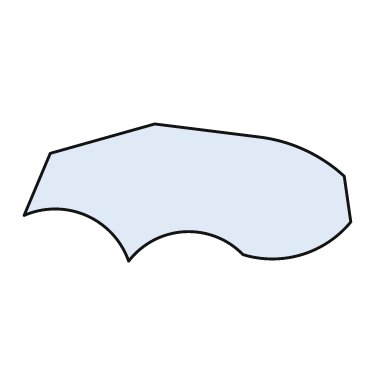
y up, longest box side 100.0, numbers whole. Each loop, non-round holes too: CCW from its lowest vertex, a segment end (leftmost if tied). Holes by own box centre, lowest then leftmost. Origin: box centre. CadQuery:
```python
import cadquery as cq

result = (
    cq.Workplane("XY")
    .moveTo(-18.0, -21.0)
    .threePointArc((-1.0, -12.0), (17.0, -19.0))
    .threePointArc((35.0, -19.0), (50.0, -9.0))
    .lineTo(48.0, 5.0)
    .threePointArc((36.0, 13.0), (22.0, 17.0))
    .lineTo(-10.0, 21.0)
    .lineTo(-42.0, 12.0)
    .lineTo(-50.0, -7.0)
    .threePointArc((-31.0, -7.0), (-18.0, -21.0))
    .close()
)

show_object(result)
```